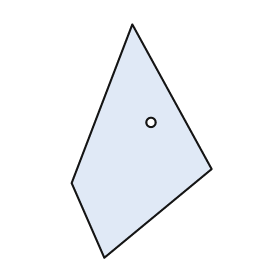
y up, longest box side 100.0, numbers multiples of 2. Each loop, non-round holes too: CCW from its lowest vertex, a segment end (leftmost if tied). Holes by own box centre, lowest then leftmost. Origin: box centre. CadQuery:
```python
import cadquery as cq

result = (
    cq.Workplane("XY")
    .moveTo(-16.0, -50.0)
    .lineTo(30.0, -12.0)
    .lineTo(-4.0, 50.0)
    .lineTo(-30.0, -18.0)
    .close()
    .moveTo(4.0, 8.0)
    .circle(2.0)
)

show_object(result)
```